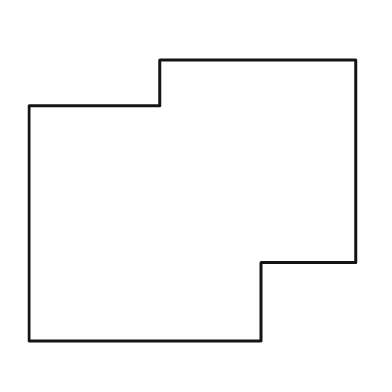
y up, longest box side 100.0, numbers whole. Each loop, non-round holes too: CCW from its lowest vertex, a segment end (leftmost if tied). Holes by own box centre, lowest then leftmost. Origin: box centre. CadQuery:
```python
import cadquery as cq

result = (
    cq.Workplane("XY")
    .moveTo(-50.0, -43.0)
    .lineTo(21.0, -43.0)
    .lineTo(21.0, -19.0)
    .lineTo(50.0, -19.0)
    .lineTo(50.0, 43.0)
    .lineTo(-10.0, 43.0)
    .lineTo(-10.0, 29.0)
    .lineTo(-50.0, 29.0)
    .close()
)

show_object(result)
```